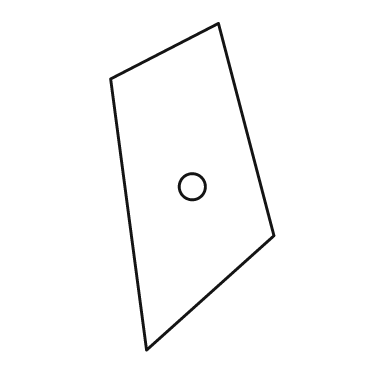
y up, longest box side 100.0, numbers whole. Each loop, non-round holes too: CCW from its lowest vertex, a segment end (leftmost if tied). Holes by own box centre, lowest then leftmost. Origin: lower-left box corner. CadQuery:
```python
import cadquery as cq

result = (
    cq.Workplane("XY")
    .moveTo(11.0, 0.0)
    .lineTo(50.0, 35.0)
    .lineTo(33.0, 100.0)
    .lineTo(0.0, 83.0)
    .close()
    .moveTo(25.0, 50.0)
    .circle(4.0)
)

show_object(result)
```